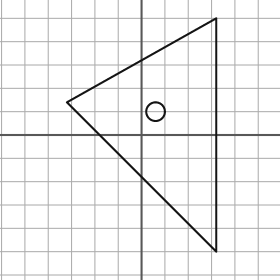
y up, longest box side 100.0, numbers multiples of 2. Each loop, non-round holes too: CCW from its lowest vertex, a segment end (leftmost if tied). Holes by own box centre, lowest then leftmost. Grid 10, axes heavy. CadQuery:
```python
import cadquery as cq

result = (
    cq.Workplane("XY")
    .moveTo(32.0, -50.0)
    .lineTo(32.0, 50.0)
    .lineTo(-32.0, 14.0)
    .close()
    .moveTo(6.0, 10.0)
    .circle(4.0)
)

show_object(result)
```